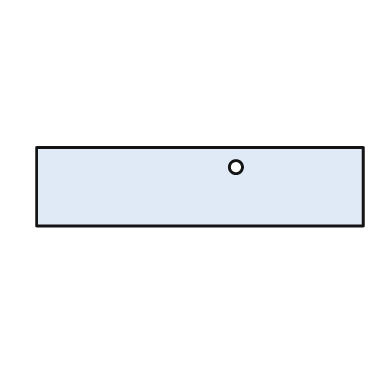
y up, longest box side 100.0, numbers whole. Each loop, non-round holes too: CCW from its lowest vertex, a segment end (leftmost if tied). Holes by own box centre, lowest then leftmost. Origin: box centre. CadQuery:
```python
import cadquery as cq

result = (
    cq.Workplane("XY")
    .moveTo(-50.0, -12.0)
    .lineTo(50.0, -12.0)
    .lineTo(50.0, 12.0)
    .lineTo(-50.0, 12.0)
    .close()
    .moveTo(11.0, 6.0)
    .circle(2.0)
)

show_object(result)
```